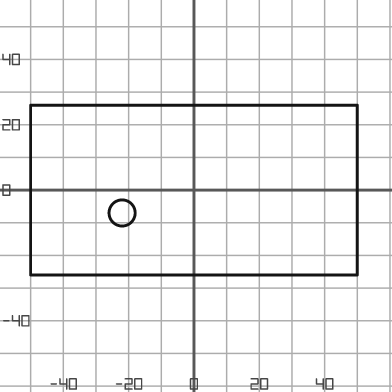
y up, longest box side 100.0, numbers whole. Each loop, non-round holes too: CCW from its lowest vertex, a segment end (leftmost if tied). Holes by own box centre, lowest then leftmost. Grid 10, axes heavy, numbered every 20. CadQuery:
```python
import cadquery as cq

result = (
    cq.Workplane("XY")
    .moveTo(-50.0, -26.0)
    .lineTo(50.0, -26.0)
    .lineTo(50.0, 26.0)
    .lineTo(-50.0, 26.0)
    .close()
    .moveTo(-22.0, -7.0)
    .circle(4.0)
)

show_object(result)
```